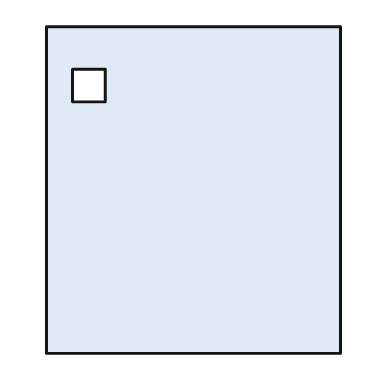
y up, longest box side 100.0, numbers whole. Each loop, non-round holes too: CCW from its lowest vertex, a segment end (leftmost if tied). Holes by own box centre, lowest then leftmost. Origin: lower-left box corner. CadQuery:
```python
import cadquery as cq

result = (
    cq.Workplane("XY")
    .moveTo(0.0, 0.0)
    .lineTo(90.0, 0.0)
    .lineTo(90.0, 100.0)
    .lineTo(0.0, 100.0)
    .close()
    .moveTo(8.0, 77.0)
    .lineTo(18.0, 77.0)
    .lineTo(18.0, 87.0)
    .lineTo(8.0, 87.0)
    .close()
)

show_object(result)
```